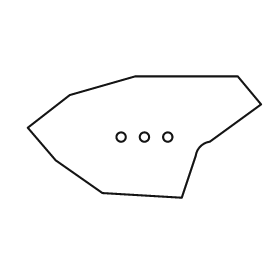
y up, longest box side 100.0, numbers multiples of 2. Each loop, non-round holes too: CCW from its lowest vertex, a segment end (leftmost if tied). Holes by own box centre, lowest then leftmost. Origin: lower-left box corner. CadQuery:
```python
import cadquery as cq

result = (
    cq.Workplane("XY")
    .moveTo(66.0, 0.0)
    .lineTo(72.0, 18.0)
    .threePointArc((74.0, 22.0), (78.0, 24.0))
    .lineTo(100.0, 40.0)
    .lineTo(90.0, 52.0)
    .lineTo(46.0, 52.0)
    .lineTo(18.0, 44.0)
    .lineTo(0.0, 30.0)
    .lineTo(12.0, 16.0)
    .lineTo(32.0, 2.0)
    .close()
    .moveTo(40.0, 26.0)
    .circle(2.0)
    .moveTo(50.0, 26.0)
    .circle(2.0)
    .moveTo(60.0, 26.0)
    .circle(2.0)
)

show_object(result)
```